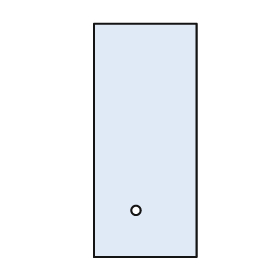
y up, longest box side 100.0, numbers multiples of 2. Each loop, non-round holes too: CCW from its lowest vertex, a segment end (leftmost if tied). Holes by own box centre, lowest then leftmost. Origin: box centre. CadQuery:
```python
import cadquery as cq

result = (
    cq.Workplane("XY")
    .moveTo(-22.0, -50.0)
    .lineTo(22.0, -50.0)
    .lineTo(22.0, 50.0)
    .lineTo(-22.0, 50.0)
    .close()
    .moveTo(-4.0, -30.0)
    .circle(2.0)
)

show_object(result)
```